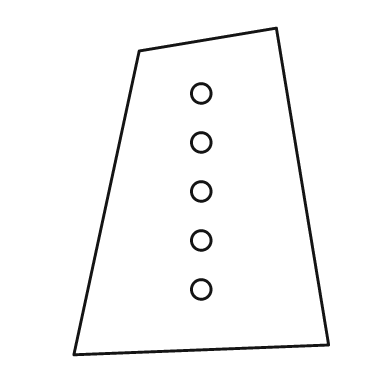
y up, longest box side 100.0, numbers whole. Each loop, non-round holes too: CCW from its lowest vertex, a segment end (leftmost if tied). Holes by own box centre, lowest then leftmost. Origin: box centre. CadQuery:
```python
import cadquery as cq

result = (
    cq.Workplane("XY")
    .moveTo(-39.0, -50.0)
    .lineTo(39.0, -47.0)
    .lineTo(23.0, 50.0)
    .lineTo(-19.0, 43.0)
    .close()
    .moveTo(0.0, -30.0)
    .circle(3.0)
    .moveTo(0.0, -15.0)
    .circle(3.0)
    .moveTo(0.0, 0.0)
    .circle(3.0)
    .moveTo(0.0, 15.0)
    .circle(3.0)
    .moveTo(0.0, 30.0)
    .circle(3.0)
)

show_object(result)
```